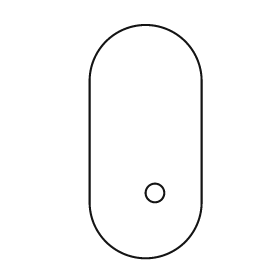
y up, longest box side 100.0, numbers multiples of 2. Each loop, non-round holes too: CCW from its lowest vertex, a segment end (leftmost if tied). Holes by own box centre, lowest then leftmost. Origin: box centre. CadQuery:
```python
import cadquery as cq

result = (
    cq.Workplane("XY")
    .moveTo(-24.0, -26.0)
    .threePointArc((0.0, -50.0), (24.0, -26.0))
    .lineTo(24.0, 26.0)
    .threePointArc((0.0, 50.0), (-24.0, 26.0))
    .close()
    .moveTo(4.0, -22.0)
    .circle(4.0)
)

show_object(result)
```